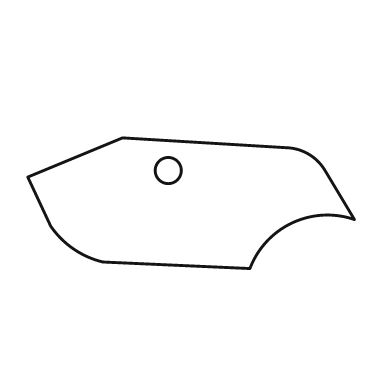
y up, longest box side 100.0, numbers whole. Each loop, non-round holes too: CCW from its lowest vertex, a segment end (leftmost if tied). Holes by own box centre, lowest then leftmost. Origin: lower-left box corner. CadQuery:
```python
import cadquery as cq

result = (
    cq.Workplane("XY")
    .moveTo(68.0, 0.0)
    .threePointArc((81.0, 14.0), (100.0, 15.0))
    .lineTo(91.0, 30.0)
    .threePointArc((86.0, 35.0), (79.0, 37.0))
    .lineTo(29.0, 40.0)
    .lineTo(0.0, 28.0)
    .lineTo(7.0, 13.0)
    .threePointArc((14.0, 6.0), (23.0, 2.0))
    .close()
    .moveTo(43.0, 30.0)
    .circle(4.0)
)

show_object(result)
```